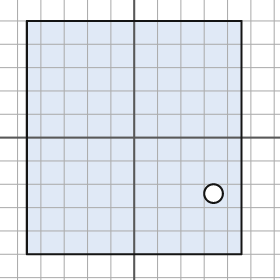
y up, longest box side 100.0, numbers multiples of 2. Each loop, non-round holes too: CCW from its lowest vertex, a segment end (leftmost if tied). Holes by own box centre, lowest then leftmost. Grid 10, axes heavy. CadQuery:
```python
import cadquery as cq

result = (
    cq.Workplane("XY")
    .moveTo(-46.0, -50.0)
    .lineTo(46.0, -50.0)
    .lineTo(46.0, 50.0)
    .lineTo(-46.0, 50.0)
    .close()
    .moveTo(34.0, -24.0)
    .circle(4.0)
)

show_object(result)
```